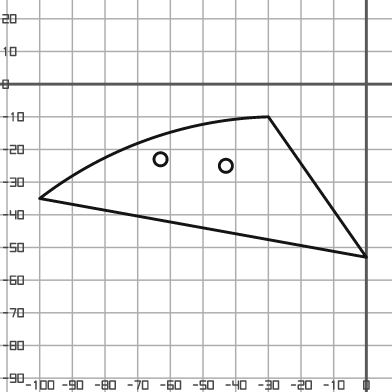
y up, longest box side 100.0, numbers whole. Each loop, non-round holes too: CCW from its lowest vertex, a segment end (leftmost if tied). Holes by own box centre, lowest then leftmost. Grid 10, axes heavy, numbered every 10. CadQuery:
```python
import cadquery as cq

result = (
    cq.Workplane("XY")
    .moveTo(0.0, -53.0)
    .lineTo(-30.0, -10.0)
    .threePointArc((-67.0, -17.0), (-100.0, -35.0))
    .close()
    .moveTo(-43.0, -25.0)
    .circle(2.0)
    .moveTo(-63.0, -23.0)
    .circle(2.0)
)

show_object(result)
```